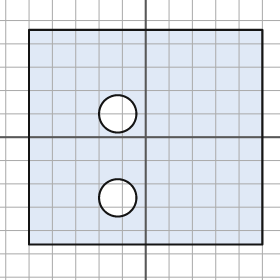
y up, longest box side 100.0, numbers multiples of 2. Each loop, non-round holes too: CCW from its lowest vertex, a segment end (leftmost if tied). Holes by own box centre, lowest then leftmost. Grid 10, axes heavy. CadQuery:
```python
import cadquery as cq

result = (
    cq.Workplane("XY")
    .moveTo(-50.0, -46.0)
    .lineTo(50.0, -46.0)
    .lineTo(50.0, 46.0)
    .lineTo(-50.0, 46.0)
    .close()
    .moveTo(-12.0, -26.0)
    .circle(8.0)
    .moveTo(-12.0, 10.0)
    .circle(8.0)
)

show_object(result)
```